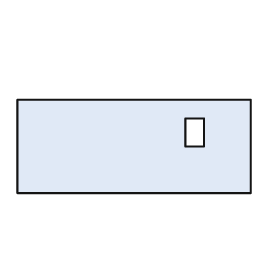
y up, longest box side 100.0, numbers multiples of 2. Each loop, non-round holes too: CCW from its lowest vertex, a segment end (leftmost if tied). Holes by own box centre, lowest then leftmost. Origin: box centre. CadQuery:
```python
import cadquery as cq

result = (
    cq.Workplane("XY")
    .moveTo(-50.0, -20.0)
    .lineTo(50.0, -20.0)
    .lineTo(50.0, 20.0)
    .lineTo(-50.0, 20.0)
    .close()
    .moveTo(22.0, 0.0)
    .lineTo(30.0, 0.0)
    .lineTo(30.0, 12.0)
    .lineTo(22.0, 12.0)
    .close()
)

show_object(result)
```